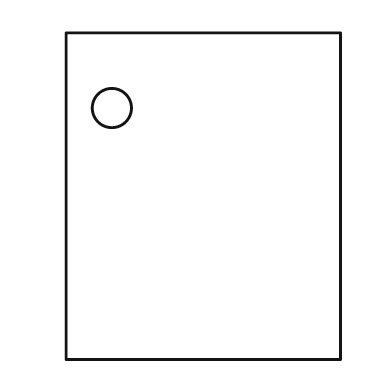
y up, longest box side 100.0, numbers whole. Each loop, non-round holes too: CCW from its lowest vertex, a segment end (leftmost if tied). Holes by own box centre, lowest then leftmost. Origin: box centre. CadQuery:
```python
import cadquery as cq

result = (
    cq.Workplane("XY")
    .moveTo(-42.0, -50.0)
    .lineTo(42.0, -50.0)
    .lineTo(42.0, 50.0)
    .lineTo(-42.0, 50.0)
    .close()
    .moveTo(-28.0, 27.0)
    .circle(6.0)
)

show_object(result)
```